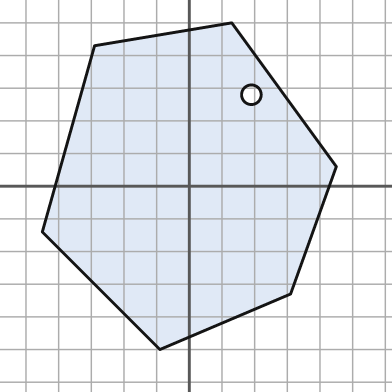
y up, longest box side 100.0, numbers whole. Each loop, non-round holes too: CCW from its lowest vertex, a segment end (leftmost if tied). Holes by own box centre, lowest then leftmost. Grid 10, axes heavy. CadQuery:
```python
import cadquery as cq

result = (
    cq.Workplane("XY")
    .moveTo(-9.0, -50.0)
    .lineTo(31.0, -33.0)
    .lineTo(45.0, 6.0)
    .lineTo(13.0, 50.0)
    .lineTo(-29.0, 43.0)
    .lineTo(-45.0, -14.0)
    .close()
    .moveTo(19.0, 28.0)
    .circle(3.0)
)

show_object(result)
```